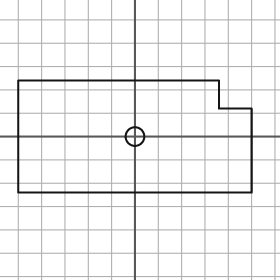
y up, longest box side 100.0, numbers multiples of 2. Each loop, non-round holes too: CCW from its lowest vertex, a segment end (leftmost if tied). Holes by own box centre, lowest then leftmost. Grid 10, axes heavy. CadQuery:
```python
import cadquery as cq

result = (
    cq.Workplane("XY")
    .moveTo(-50.0, -24.0)
    .lineTo(50.0, -24.0)
    .lineTo(50.0, 12.0)
    .lineTo(36.0, 12.0)
    .lineTo(36.0, 24.0)
    .lineTo(-50.0, 24.0)
    .close()
    .moveTo(0.0, 0.0)
    .circle(4.0)
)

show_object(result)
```